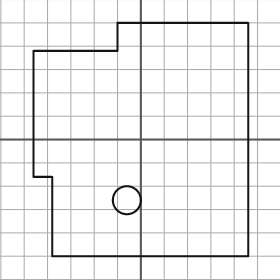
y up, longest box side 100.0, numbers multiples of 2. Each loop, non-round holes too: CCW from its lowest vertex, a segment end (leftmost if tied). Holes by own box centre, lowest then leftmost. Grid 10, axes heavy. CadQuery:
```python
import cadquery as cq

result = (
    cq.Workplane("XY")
    .moveTo(-38.0, -50.0)
    .lineTo(46.0, -50.0)
    .lineTo(46.0, 50.0)
    .lineTo(-10.0, 50.0)
    .lineTo(-10.0, 38.0)
    .lineTo(-46.0, 38.0)
    .lineTo(-46.0, -16.0)
    .lineTo(-38.0, -16.0)
    .close()
    .moveTo(-6.0, -26.0)
    .circle(6.0)
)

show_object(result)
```